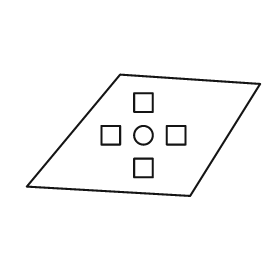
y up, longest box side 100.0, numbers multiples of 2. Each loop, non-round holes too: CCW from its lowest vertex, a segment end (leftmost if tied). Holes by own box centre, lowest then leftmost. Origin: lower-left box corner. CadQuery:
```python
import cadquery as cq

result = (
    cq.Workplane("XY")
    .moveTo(70.0, 0.0)
    .lineTo(100.0, 48.0)
    .lineTo(40.0, 52.0)
    .lineTo(0.0, 4.0)
    .close()
    .moveTo(46.0, 8.0)
    .lineTo(54.0, 8.0)
    .lineTo(54.0, 16.0)
    .lineTo(46.0, 16.0)
    .close()
    .moveTo(32.0, 22.0)
    .lineTo(40.0, 22.0)
    .lineTo(40.0, 30.0)
    .lineTo(32.0, 30.0)
    .close()
    .moveTo(50.0, 26.0)
    .circle(4.0)
    .moveTo(60.0, 22.0)
    .lineTo(68.0, 22.0)
    .lineTo(68.0, 30.0)
    .lineTo(60.0, 30.0)
    .close()
    .moveTo(46.0, 36.0)
    .lineTo(54.0, 36.0)
    .lineTo(54.0, 44.0)
    .lineTo(46.0, 44.0)
    .close()
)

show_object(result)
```